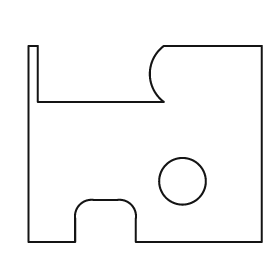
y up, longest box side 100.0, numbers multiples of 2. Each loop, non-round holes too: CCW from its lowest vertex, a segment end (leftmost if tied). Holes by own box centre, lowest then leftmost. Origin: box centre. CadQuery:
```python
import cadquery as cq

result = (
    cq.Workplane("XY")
    .moveTo(-50.0, -42.0)
    .lineTo(-30.0, -42.0)
    .lineTo(-30.0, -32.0)
    .threePointArc((-28.0, -26.0), (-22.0, -24.0))
    .lineTo(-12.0, -24.0)
    .threePointArc((-6.0, -26.0), (-4.0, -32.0))
    .lineTo(-4.0, -42.0)
    .lineTo(50.0, -42.0)
    .lineTo(50.0, 42.0)
    .lineTo(8.0, 42.0)
    .threePointArc((2.0, 30.0), (8.0, 18.0))
    .lineTo(-46.0, 18.0)
    .lineTo(-46.0, 42.0)
    .lineTo(-50.0, 42.0)
    .close()
    .moveTo(16.0, -16.0)
    .circle(10.0)
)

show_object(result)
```